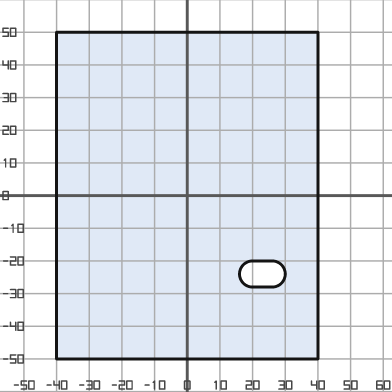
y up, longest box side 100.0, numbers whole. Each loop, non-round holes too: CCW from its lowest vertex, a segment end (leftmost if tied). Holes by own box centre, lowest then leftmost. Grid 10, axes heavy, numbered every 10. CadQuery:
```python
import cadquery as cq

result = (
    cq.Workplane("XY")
    .moveTo(-40.0, -50.0)
    .lineTo(40.0, -50.0)
    .lineTo(40.0, 50.0)
    .lineTo(-40.0, 50.0)
    .close()
    .moveTo(20.0, -28.0)
    .lineTo(26.0, -28.0)
    .threePointArc((30.0, -24.0), (26.0, -20.0))
    .lineTo(20.0, -20.0)
    .threePointArc((16.0, -24.0), (20.0, -28.0))
    .close()
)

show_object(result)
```